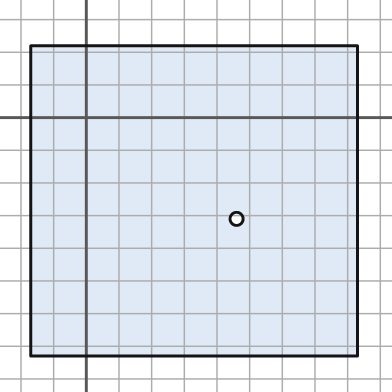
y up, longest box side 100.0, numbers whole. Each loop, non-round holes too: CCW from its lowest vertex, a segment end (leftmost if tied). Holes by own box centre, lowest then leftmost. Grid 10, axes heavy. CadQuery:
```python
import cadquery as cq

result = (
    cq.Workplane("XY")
    .moveTo(-17.0, -73.0)
    .lineTo(83.0, -73.0)
    .lineTo(83.0, 22.0)
    .lineTo(-17.0, 22.0)
    .close()
    .moveTo(46.0, -31.0)
    .circle(2.0)
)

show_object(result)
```